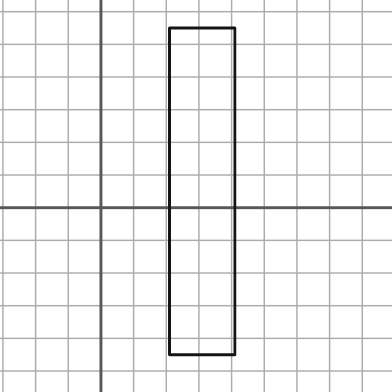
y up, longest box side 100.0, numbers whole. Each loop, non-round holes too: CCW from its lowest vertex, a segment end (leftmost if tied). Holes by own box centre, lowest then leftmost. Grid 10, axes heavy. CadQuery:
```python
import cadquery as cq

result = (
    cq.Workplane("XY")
    .moveTo(21.0, -45.0)
    .lineTo(41.0, -45.0)
    .lineTo(41.0, 55.0)
    .lineTo(21.0, 55.0)
    .close()
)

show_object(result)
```